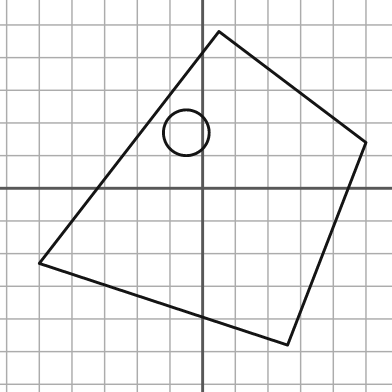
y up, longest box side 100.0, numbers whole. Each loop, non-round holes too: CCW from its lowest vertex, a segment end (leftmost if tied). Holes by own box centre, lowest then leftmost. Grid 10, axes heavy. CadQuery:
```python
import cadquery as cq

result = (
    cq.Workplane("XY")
    .moveTo(26.0, -48.0)
    .lineTo(50.0, 14.0)
    .lineTo(5.0, 48.0)
    .lineTo(-50.0, -23.0)
    .close()
    .moveTo(-5.0, 17.0)
    .circle(7.0)
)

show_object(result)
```